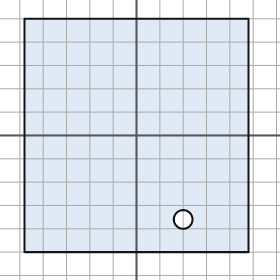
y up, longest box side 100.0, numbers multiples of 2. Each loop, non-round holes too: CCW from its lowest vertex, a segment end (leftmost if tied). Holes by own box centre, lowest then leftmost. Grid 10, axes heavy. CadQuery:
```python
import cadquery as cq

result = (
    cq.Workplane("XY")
    .moveTo(-48.0, -50.0)
    .lineTo(48.0, -50.0)
    .lineTo(48.0, 50.0)
    .lineTo(-48.0, 50.0)
    .close()
    .moveTo(20.0, -36.0)
    .circle(4.0)
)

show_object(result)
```